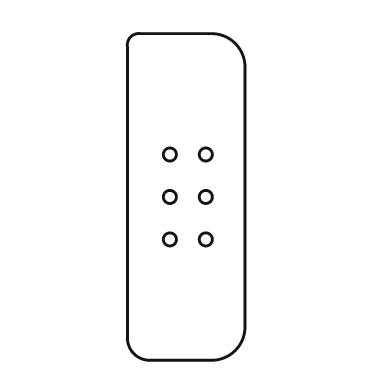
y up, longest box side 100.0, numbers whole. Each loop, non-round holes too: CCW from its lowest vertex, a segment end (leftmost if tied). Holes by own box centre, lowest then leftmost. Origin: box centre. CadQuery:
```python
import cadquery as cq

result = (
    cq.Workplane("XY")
    .moveTo(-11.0, -50.0)
    .lineTo(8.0, -50.0)
    .threePointArc((15.0, -47.0), (18.0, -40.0))
    .lineTo(18.0, 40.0)
    .threePointArc((15.0, 47.0), (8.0, 50.0))
    .lineTo(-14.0, 50.0)
    .threePointArc((-17.0, 49.0), (-18.0, 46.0))
    .lineTo(-18.0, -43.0)
    .threePointArc((-16.0, -48.0), (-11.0, -50.0))
    .close()
    .moveTo(-5.0, -13.0)
    .circle(2.0)
    .moveTo(6.0, -13.0)
    .circle(2.0)
    .moveTo(-5.0, 0.0)
    .circle(2.0)
    .moveTo(6.0, 0.0)
    .circle(2.0)
    .moveTo(-5.0, 13.0)
    .circle(2.0)
    .moveTo(6.0, 13.0)
    .circle(2.0)
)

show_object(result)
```